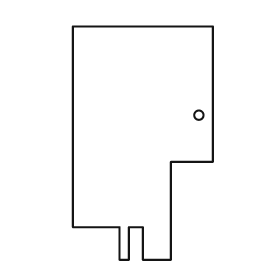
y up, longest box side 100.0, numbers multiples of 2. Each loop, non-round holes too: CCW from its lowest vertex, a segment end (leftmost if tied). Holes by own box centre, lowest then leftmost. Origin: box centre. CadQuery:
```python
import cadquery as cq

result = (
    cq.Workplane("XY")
    .moveTo(-10.0, -50.0)
    .lineTo(-6.0, -50.0)
    .lineTo(-6.0, -36.0)
    .lineTo(0.0, -36.0)
    .lineTo(0.0, -50.0)
    .lineTo(12.0, -50.0)
    .lineTo(12.0, -8.0)
    .lineTo(30.0, -8.0)
    .lineTo(30.0, 50.0)
    .lineTo(-30.0, 50.0)
    .lineTo(-30.0, -36.0)
    .lineTo(-10.0, -36.0)
    .close()
    .moveTo(24.0, 12.0)
    .circle(2.0)
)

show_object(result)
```